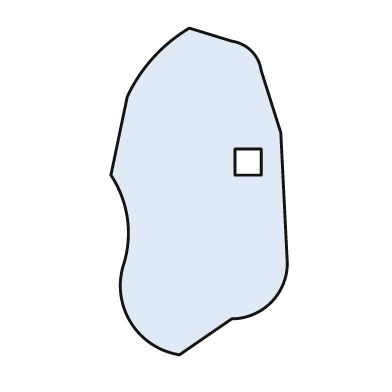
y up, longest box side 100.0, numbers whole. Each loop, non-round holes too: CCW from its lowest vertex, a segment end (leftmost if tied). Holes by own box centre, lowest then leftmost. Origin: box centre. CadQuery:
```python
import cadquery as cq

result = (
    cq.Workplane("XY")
    .moveTo(-6.0, -50.0)
    .lineTo(10.0, -39.0)
    .threePointArc((22.0, -34.0), (27.0, -22.0))
    .lineTo(25.0, 18.0)
    .lineTo(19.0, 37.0)
    .threePointArc((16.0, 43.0), (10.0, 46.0))
    .lineTo(-3.0, 50.0)
    .threePointArc((-14.0, 41.0), (-22.0, 29.0))
    .lineTo(-27.0, 5.0)
    .threePointArc((-22.0, -8.0), (-23.0, -22.0))
    .threePointArc((-21.0, -40.0), (-6.0, -50.0))
    .close()
    .moveTo(11.0, 5.0)
    .lineTo(19.0, 5.0)
    .lineTo(19.0, 13.0)
    .lineTo(11.0, 13.0)
    .close()
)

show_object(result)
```